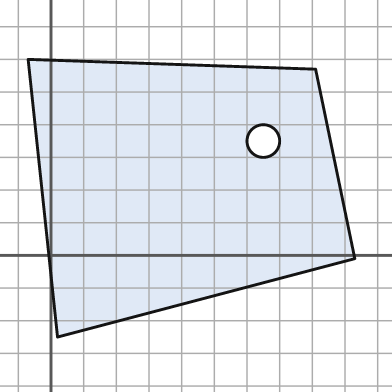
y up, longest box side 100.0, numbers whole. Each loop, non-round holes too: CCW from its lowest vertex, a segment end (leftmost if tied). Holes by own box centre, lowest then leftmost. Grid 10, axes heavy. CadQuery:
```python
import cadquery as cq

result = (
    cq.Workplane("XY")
    .moveTo(2.0, -25.0)
    .lineTo(93.0, -1.0)
    .lineTo(81.0, 57.0)
    .lineTo(-7.0, 60.0)
    .close()
    .moveTo(65.0, 35.0)
    .circle(5.0)
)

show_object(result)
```